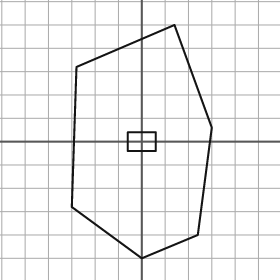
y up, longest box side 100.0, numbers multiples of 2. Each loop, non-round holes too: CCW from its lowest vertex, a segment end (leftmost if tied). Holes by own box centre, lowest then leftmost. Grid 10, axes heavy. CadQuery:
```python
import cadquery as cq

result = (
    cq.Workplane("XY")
    .moveTo(0.0, -50.0)
    .lineTo(24.0, -40.0)
    .lineTo(30.0, 6.0)
    .lineTo(14.0, 50.0)
    .lineTo(-28.0, 32.0)
    .lineTo(-30.0, -28.0)
    .close()
    .moveTo(-6.0, -4.0)
    .lineTo(6.0, -4.0)
    .lineTo(6.0, 4.0)
    .lineTo(-6.0, 4.0)
    .close()
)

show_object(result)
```